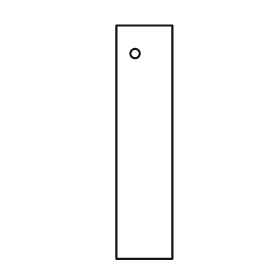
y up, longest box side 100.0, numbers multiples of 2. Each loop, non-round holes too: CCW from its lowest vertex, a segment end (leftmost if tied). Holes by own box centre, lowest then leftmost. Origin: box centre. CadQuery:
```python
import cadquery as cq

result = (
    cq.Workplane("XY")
    .moveTo(-12.0, -50.0)
    .lineTo(12.0, -50.0)
    .lineTo(12.0, 50.0)
    .lineTo(-12.0, 50.0)
    .close()
    .moveTo(-4.0, 38.0)
    .circle(2.0)
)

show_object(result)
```